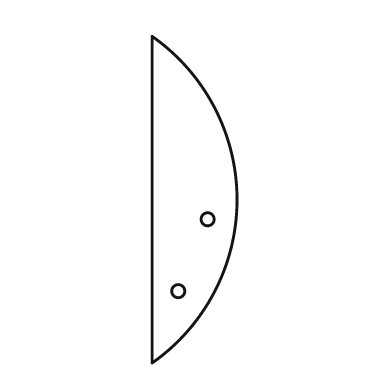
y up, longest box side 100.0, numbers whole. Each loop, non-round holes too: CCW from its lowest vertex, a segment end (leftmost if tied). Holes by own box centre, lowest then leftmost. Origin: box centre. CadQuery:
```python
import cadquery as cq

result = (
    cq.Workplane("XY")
    .moveTo(-13.0, -50.0)
    .threePointArc((13.0, 0.0), (-13.0, 50.0))
    .close()
    .moveTo(-5.0, -28.0)
    .circle(2.0)
    .moveTo(4.0, -6.0)
    .circle(2.0)
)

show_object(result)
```